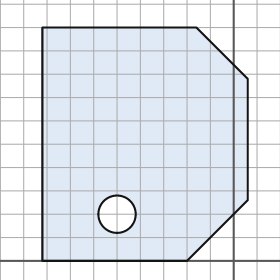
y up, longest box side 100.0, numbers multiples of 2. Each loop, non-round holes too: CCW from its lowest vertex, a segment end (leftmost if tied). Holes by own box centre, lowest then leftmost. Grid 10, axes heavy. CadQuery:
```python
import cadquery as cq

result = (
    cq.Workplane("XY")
    .moveTo(-82.0, 0.0)
    .lineTo(-20.0, 0.0)
    .lineTo(6.0, 26.0)
    .lineTo(6.0, 78.0)
    .lineTo(-16.0, 100.0)
    .lineTo(-82.0, 100.0)
    .close()
    .moveTo(-50.0, 20.0)
    .circle(8.0)
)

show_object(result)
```